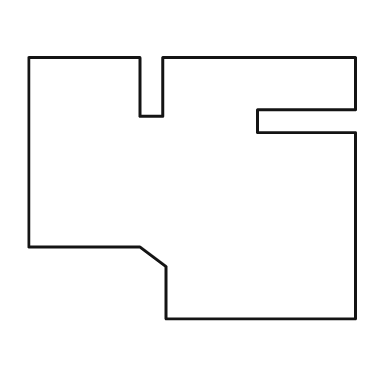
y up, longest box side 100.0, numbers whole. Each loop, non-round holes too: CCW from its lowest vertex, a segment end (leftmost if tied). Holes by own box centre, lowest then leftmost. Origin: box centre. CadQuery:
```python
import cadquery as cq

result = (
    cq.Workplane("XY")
    .moveTo(-8.0, -40.0)
    .lineTo(50.0, -40.0)
    .lineTo(50.0, 17.0)
    .lineTo(20.0, 17.0)
    .lineTo(20.0, 24.0)
    .lineTo(50.0, 24.0)
    .lineTo(50.0, 40.0)
    .lineTo(-9.0, 40.0)
    .lineTo(-9.0, 22.0)
    .lineTo(-16.0, 22.0)
    .lineTo(-16.0, 40.0)
    .lineTo(-50.0, 40.0)
    .lineTo(-50.0, -18.0)
    .lineTo(-16.0, -18.0)
    .lineTo(-8.0, -24.0)
    .close()
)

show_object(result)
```